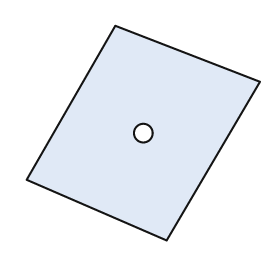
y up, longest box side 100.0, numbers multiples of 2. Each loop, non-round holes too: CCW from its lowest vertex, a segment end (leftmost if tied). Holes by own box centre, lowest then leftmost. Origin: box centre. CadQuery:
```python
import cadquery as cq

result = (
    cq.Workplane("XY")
    .moveTo(10.0, -46.0)
    .lineTo(50.0, 22.0)
    .lineTo(-12.0, 46.0)
    .lineTo(-50.0, -20.0)
    .close()
    .moveTo(0.0, 0.0)
    .circle(4.0)
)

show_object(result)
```